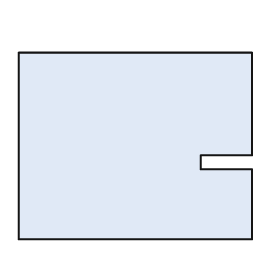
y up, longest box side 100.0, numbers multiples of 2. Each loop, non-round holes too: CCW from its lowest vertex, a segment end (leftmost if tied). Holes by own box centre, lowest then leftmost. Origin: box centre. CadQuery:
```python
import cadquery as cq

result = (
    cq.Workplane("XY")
    .moveTo(-50.0, -40.0)
    .lineTo(50.0, -40.0)
    .lineTo(50.0, -10.0)
    .lineTo(28.0, -10.0)
    .lineTo(28.0, -4.0)
    .lineTo(50.0, -4.0)
    .lineTo(50.0, 40.0)
    .lineTo(-50.0, 40.0)
    .close()
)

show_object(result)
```